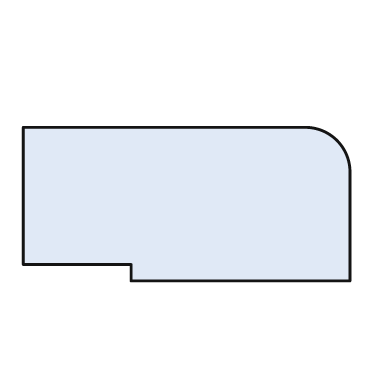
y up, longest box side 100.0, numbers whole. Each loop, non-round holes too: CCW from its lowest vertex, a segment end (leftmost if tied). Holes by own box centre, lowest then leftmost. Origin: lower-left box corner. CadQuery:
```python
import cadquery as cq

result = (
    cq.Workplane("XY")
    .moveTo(33.0, 0.0)
    .lineTo(100.0, 0.0)
    .lineTo(100.0, 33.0)
    .threePointArc((96.0, 43.0), (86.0, 47.0))
    .lineTo(0.0, 47.0)
    .lineTo(0.0, 5.0)
    .lineTo(33.0, 5.0)
    .close()
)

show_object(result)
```